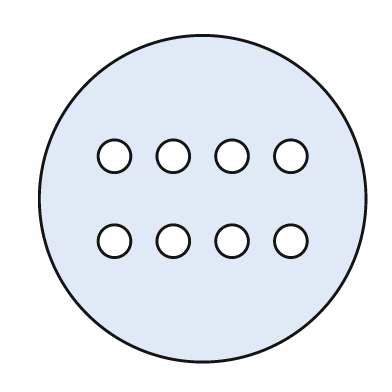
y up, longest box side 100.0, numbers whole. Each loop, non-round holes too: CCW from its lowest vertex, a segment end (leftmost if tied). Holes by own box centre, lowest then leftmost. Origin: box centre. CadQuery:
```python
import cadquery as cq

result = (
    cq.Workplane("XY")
    .moveTo(0.0, 0.0)
    .circle(50.0)
    .moveTo(-27.0, -13.0)
    .circle(5.0)
    .moveTo(-9.0, -13.0)
    .circle(5.0)
    .moveTo(9.0, -13.0)
    .circle(5.0)
    .moveTo(27.0, -13.0)
    .circle(5.0)
    .moveTo(-27.0, 13.0)
    .circle(5.0)
    .moveTo(-9.0, 13.0)
    .circle(5.0)
    .moveTo(9.0, 13.0)
    .circle(5.0)
    .moveTo(27.0, 13.0)
    .circle(5.0)
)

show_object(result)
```